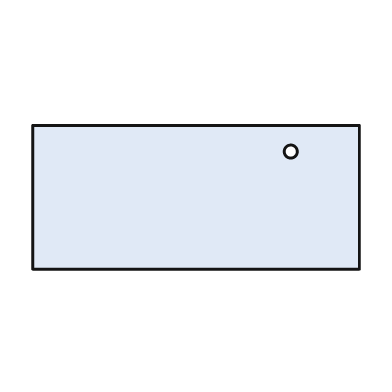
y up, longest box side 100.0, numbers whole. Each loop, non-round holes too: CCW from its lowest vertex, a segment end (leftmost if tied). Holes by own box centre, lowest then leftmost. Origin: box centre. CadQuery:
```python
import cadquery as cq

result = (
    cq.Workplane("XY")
    .moveTo(-50.0, -22.0)
    .lineTo(50.0, -22.0)
    .lineTo(50.0, 22.0)
    .lineTo(-50.0, 22.0)
    .close()
    .moveTo(29.0, 14.0)
    .circle(2.0)
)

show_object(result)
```